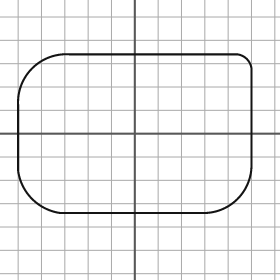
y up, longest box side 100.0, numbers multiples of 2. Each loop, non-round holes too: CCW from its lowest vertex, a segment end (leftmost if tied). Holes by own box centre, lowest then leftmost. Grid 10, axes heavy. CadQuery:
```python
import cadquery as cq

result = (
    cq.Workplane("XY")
    .moveTo(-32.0, -34.0)
    .lineTo(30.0, -34.0)
    .threePointArc((44.0, -28.0), (50.0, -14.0))
    .lineTo(50.0, 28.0)
    .threePointArc((48.0, 32.0), (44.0, 34.0))
    .lineTo(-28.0, 34.0)
    .threePointArc((-44.0, 28.0), (-50.0, 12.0))
    .lineTo(-50.0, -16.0)
    .threePointArc((-44.0, -28.0), (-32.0, -34.0))
    .close()
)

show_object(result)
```